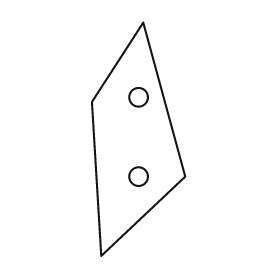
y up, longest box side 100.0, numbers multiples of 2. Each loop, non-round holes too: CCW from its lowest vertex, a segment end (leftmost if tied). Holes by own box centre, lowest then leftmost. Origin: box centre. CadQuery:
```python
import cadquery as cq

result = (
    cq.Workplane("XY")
    .moveTo(-16.0, -50.0)
    .lineTo(20.0, -16.0)
    .lineTo(2.0, 50.0)
    .lineTo(-20.0, 16.0)
    .close()
    .moveTo(0.0, -16.0)
    .circle(4.0)
    .moveTo(0.0, 18.0)
    .circle(4.0)
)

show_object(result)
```